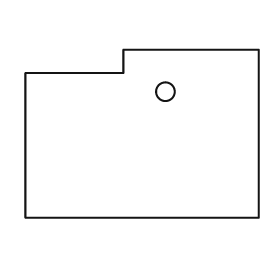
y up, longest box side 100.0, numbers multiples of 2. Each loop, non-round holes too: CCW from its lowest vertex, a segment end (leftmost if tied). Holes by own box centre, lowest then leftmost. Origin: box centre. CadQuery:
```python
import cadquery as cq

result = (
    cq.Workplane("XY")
    .moveTo(-50.0, -36.0)
    .lineTo(50.0, -36.0)
    .lineTo(50.0, 36.0)
    .lineTo(-8.0, 36.0)
    .lineTo(-8.0, 26.0)
    .lineTo(-50.0, 26.0)
    .close()
    .moveTo(10.0, 18.0)
    .circle(4.0)
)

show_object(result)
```